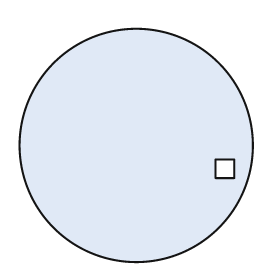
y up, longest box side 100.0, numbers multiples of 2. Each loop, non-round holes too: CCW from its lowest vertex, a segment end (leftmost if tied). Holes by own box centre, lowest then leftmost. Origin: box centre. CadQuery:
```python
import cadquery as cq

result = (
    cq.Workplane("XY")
    .moveTo(0.0, 0.0)
    .circle(50.0)
    .moveTo(34.0, -14.0)
    .lineTo(42.0, -14.0)
    .lineTo(42.0, -6.0)
    .lineTo(34.0, -6.0)
    .close()
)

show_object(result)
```